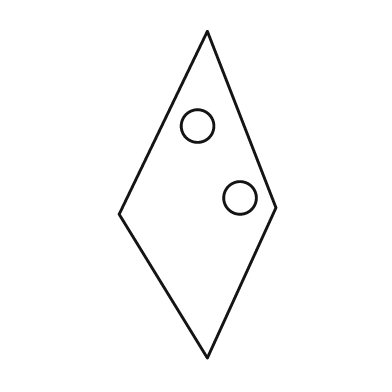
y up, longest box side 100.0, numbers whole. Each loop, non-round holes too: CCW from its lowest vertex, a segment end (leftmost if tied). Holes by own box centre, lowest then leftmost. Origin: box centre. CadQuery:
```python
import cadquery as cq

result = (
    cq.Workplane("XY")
    .moveTo(3.0, -50.0)
    .lineTo(24.0, -4.0)
    .lineTo(3.0, 50.0)
    .lineTo(-24.0, -6.0)
    .close()
    .moveTo(13.0, -1.0)
    .circle(5.0)
    .moveTo(0.0, 21.0)
    .circle(5.0)
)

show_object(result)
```